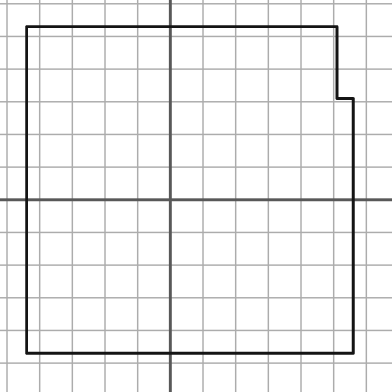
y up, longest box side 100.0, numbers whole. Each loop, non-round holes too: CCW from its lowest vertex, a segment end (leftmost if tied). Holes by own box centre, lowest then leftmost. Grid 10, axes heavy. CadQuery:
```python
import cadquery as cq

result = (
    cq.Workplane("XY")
    .moveTo(-44.0, -47.0)
    .lineTo(56.0, -47.0)
    .lineTo(56.0, 31.0)
    .lineTo(51.0, 31.0)
    .lineTo(51.0, 53.0)
    .lineTo(-44.0, 53.0)
    .close()
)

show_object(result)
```